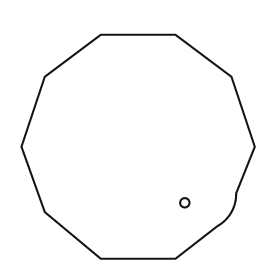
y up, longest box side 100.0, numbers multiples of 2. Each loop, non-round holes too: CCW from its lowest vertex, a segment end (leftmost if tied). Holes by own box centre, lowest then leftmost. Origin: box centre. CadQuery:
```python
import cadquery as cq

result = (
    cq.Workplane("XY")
    .moveTo(-16.0, -48.0)
    .lineTo(16.0, -48.0)
    .lineTo(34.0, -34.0)
    .threePointArc((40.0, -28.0), (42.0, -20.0))
    .lineTo(50.0, 0.0)
    .lineTo(40.0, 30.0)
    .lineTo(16.0, 48.0)
    .lineTo(-16.0, 48.0)
    .lineTo(-40.0, 30.0)
    .lineTo(-50.0, 0.0)
    .lineTo(-40.0, -28.0)
    .close()
    .moveTo(20.0, -24.0)
    .circle(2.0)
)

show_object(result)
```